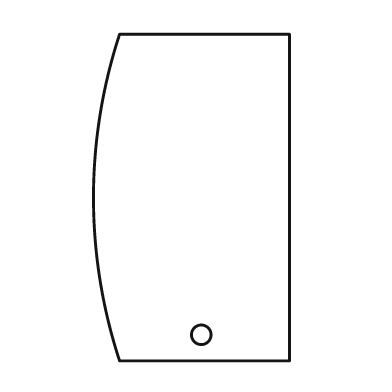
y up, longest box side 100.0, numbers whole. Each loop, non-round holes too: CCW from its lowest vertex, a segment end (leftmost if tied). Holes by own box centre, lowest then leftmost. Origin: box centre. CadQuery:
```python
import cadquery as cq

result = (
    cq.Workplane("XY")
    .moveTo(-22.0, -50.0)
    .lineTo(30.0, -50.0)
    .lineTo(30.0, 50.0)
    .lineTo(-22.0, 50.0)
    .threePointArc((-30.0, 0.0), (-22.0, -50.0))
    .close()
    .moveTo(3.0, -42.0)
    .circle(3.0)
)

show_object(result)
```